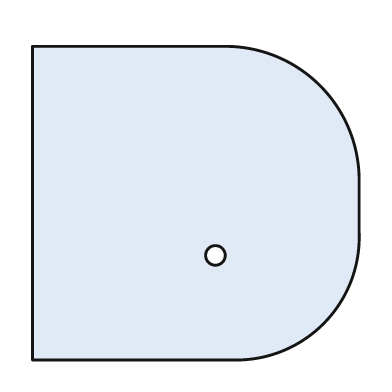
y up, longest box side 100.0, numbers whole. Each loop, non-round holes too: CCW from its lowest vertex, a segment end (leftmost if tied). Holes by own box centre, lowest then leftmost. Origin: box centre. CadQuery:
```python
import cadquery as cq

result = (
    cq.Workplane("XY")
    .moveTo(-50.0, -48.0)
    .lineTo(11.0, -48.0)
    .threePointArc((39.0, -37.0), (50.0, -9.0))
    .lineTo(50.0, 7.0)
    .threePointArc((38.0, 36.0), (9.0, 48.0))
    .lineTo(-50.0, 48.0)
    .close()
    .moveTo(6.0, -16.0)
    .circle(3.0)
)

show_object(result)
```